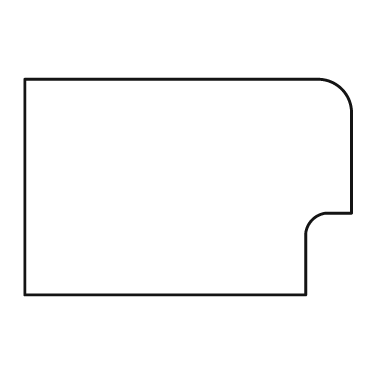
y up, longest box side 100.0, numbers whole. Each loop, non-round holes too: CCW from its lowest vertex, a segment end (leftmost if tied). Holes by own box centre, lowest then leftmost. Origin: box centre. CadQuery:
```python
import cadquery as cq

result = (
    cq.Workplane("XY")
    .moveTo(-50.0, -33.0)
    .lineTo(36.0, -33.0)
    .lineTo(36.0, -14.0)
    .threePointArc((38.0, -10.0), (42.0, -8.0))
    .lineTo(50.0, -8.0)
    .lineTo(50.0, 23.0)
    .threePointArc((47.0, 30.0), (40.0, 33.0))
    .lineTo(-50.0, 33.0)
    .close()
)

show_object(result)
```